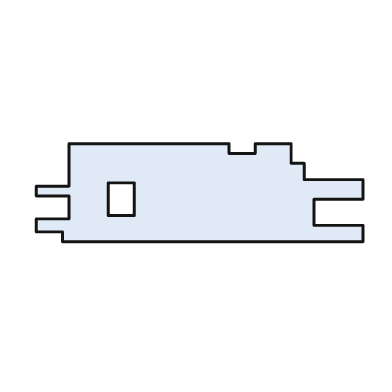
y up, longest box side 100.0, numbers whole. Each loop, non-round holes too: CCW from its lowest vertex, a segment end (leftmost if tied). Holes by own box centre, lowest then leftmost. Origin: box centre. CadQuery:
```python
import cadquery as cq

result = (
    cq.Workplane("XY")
    .moveTo(-42.0, -15.0)
    .lineTo(50.0, -15.0)
    .lineTo(50.0, -10.0)
    .lineTo(35.0, -10.0)
    .lineTo(35.0, -2.0)
    .lineTo(50.0, -2.0)
    .lineTo(50.0, 4.0)
    .lineTo(32.0, 4.0)
    .lineTo(32.0, 9.0)
    .lineTo(28.0, 9.0)
    .lineTo(28.0, 15.0)
    .lineTo(17.0, 15.0)
    .lineTo(17.0, 12.0)
    .lineTo(9.0, 12.0)
    .lineTo(9.0, 15.0)
    .lineTo(-40.0, 15.0)
    .lineTo(-40.0, 2.0)
    .lineTo(-50.0, 2.0)
    .lineTo(-50.0, -1.0)
    .lineTo(-40.0, -1.0)
    .lineTo(-40.0, -8.0)
    .lineTo(-50.0, -8.0)
    .lineTo(-50.0, -12.0)
    .lineTo(-42.0, -12.0)
    .close()
    .moveTo(-28.0, -7.0)
    .lineTo(-20.0, -7.0)
    .lineTo(-20.0, 3.0)
    .lineTo(-28.0, 3.0)
    .close()
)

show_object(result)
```